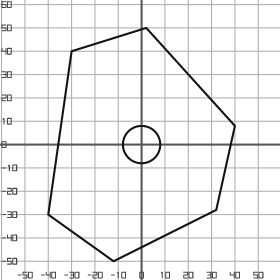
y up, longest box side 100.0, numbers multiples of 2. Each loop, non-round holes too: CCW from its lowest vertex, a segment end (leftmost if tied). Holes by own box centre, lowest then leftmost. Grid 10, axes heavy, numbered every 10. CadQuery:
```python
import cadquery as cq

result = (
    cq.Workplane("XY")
    .moveTo(-12.0, -50.0)
    .lineTo(32.0, -28.0)
    .lineTo(40.0, 8.0)
    .lineTo(2.0, 50.0)
    .lineTo(-30.0, 40.0)
    .lineTo(-40.0, -30.0)
    .close()
    .moveTo(0.0, 0.0)
    .circle(8.0)
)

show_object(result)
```